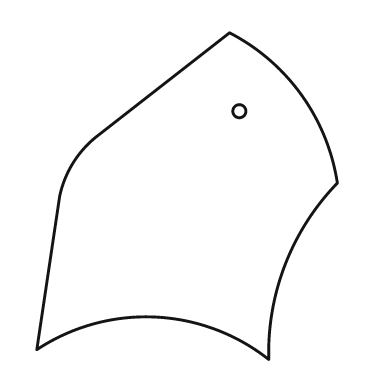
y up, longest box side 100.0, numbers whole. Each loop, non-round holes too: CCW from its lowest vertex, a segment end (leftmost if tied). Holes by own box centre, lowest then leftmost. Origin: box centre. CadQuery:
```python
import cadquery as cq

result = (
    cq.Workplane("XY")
    .moveTo(25.0, -50.0)
    .threePointArc((30.0, -21.0), (46.0, 4.0))
    .threePointArc((35.0, 31.0), (13.0, 50.0))
    .lineTo(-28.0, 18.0)
    .threePointArc((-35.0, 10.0), (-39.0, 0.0))
    .lineTo(-46.0, -47.0)
    .threePointArc((-10.0, -37.0), (25.0, -50.0))
    .close()
    .moveTo(16.0, 26.0)
    .circle(2.0)
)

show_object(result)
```